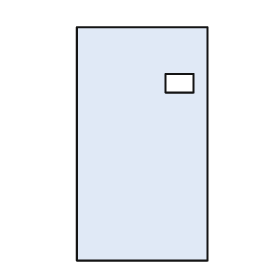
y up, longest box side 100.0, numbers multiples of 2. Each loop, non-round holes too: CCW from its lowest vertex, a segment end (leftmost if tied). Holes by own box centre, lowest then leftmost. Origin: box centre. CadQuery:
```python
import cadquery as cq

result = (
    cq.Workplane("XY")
    .moveTo(-28.0, -50.0)
    .lineTo(28.0, -50.0)
    .lineTo(28.0, 50.0)
    .lineTo(-28.0, 50.0)
    .close()
    .moveTo(10.0, 22.0)
    .lineTo(22.0, 22.0)
    .lineTo(22.0, 30.0)
    .lineTo(10.0, 30.0)
    .close()
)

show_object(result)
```